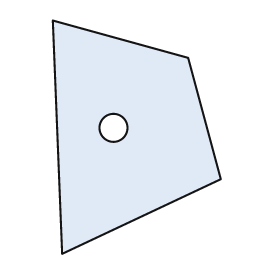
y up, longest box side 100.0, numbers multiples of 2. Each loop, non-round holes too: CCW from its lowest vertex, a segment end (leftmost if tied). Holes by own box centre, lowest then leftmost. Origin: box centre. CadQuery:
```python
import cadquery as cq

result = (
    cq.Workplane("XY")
    .moveTo(-32.0, -50.0)
    .lineTo(36.0, -18.0)
    .lineTo(22.0, 34.0)
    .lineTo(-36.0, 50.0)
    .close()
    .moveTo(-10.0, 4.0)
    .circle(6.0)
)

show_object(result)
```